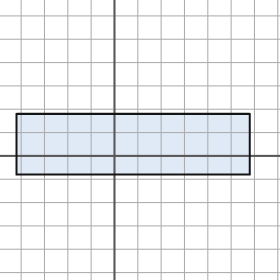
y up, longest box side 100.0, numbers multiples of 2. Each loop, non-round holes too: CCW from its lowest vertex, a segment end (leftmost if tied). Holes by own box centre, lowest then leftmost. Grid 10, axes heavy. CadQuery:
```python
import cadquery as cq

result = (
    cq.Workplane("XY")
    .moveTo(-42.0, -8.0)
    .lineTo(58.0, -8.0)
    .lineTo(58.0, 18.0)
    .lineTo(-42.0, 18.0)
    .close()
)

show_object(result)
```